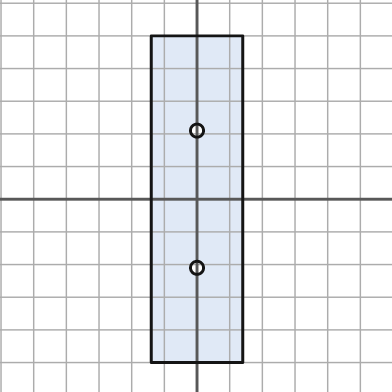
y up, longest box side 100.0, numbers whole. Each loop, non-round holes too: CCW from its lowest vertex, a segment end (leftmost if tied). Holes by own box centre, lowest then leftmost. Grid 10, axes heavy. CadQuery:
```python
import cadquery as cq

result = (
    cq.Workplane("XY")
    .moveTo(-14.0, -50.0)
    .lineTo(14.0, -50.0)
    .lineTo(14.0, 50.0)
    .lineTo(-14.0, 50.0)
    .close()
    .moveTo(0.0, -21.0)
    .circle(2.0)
    .moveTo(0.0, 21.0)
    .circle(2.0)
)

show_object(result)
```